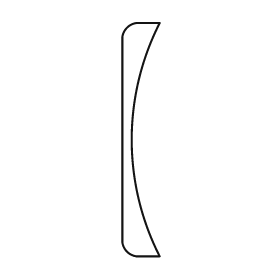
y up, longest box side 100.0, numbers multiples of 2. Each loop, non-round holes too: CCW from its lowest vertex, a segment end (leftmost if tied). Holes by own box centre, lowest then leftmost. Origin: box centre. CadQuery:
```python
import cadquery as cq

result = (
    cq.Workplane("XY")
    .moveTo(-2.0, -50.0)
    .lineTo(8.0, -50.0)
    .threePointArc((-4.0, 0.0), (8.0, 50.0))
    .lineTo(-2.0, 50.0)
    .threePointArc((-6.0, 48.0), (-8.0, 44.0))
    .lineTo(-8.0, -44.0)
    .threePointArc((-6.0, -48.0), (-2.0, -50.0))
    .close()
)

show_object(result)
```